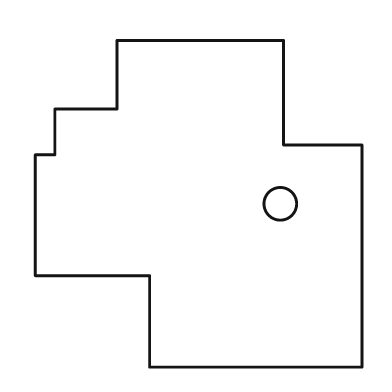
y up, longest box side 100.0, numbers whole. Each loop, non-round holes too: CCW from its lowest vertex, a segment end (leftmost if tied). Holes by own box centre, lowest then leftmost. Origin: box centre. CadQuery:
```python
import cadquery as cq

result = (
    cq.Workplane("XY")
    .moveTo(-15.0, -50.0)
    .lineTo(50.0, -50.0)
    .lineTo(50.0, 18.0)
    .lineTo(26.0, 18.0)
    .lineTo(26.0, 50.0)
    .lineTo(-25.0, 50.0)
    .lineTo(-25.0, 29.0)
    .lineTo(-44.0, 29.0)
    .lineTo(-44.0, 15.0)
    .lineTo(-50.0, 15.0)
    .lineTo(-50.0, -22.0)
    .lineTo(-15.0, -22.0)
    .close()
    .moveTo(25.0, 0.0)
    .circle(5.0)
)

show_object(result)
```